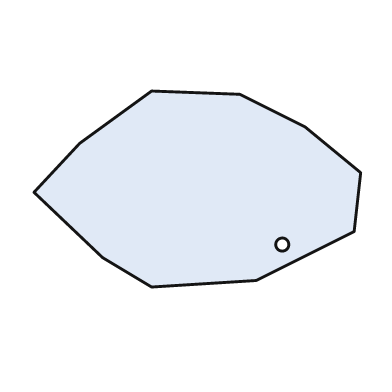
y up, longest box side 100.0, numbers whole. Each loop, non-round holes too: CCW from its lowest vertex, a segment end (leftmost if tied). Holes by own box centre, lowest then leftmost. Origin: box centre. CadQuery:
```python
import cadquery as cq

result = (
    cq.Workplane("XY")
    .moveTo(-14.0, -30.0)
    .lineTo(18.0, -28.0)
    .lineTo(48.0, -13.0)
    .lineTo(50.0, 5.0)
    .lineTo(33.0, 19.0)
    .lineTo(13.0, 29.0)
    .lineTo(-14.0, 30.0)
    .lineTo(-36.0, 14.0)
    .lineTo(-50.0, -1.0)
    .lineTo(-29.0, -21.0)
    .close()
    .moveTo(26.0, -17.0)
    .circle(2.0)
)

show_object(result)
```